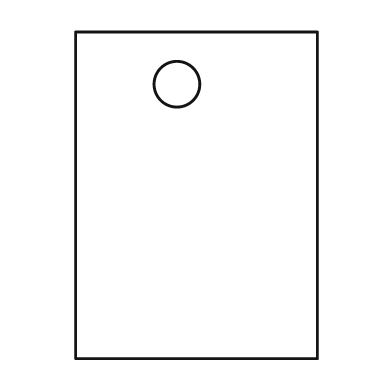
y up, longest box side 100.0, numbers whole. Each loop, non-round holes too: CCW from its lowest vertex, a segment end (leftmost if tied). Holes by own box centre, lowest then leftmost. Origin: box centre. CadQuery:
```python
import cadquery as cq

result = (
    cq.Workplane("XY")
    .moveTo(-37.0, -50.0)
    .lineTo(37.0, -50.0)
    .lineTo(37.0, 50.0)
    .lineTo(-37.0, 50.0)
    .close()
    .moveTo(-6.0, 34.0)
    .circle(7.0)
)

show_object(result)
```